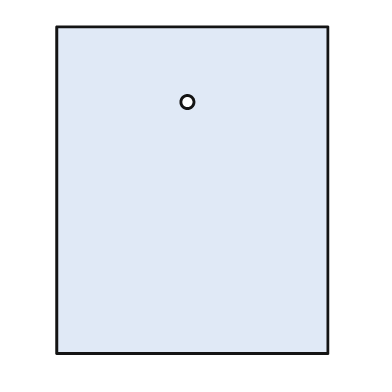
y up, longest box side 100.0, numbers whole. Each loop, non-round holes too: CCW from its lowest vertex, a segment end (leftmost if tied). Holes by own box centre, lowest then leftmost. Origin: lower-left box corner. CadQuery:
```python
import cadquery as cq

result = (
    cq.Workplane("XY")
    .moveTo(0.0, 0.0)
    .lineTo(83.0, 0.0)
    .lineTo(83.0, 100.0)
    .lineTo(0.0, 100.0)
    .close()
    .moveTo(40.0, 77.0)
    .circle(2.0)
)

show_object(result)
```